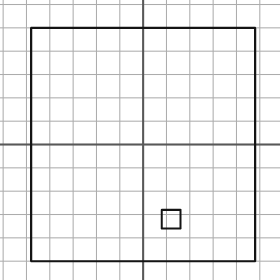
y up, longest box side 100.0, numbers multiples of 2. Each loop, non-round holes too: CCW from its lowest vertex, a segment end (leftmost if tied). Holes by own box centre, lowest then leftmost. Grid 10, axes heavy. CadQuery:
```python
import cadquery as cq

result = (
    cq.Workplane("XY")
    .moveTo(-48.0, -50.0)
    .lineTo(48.0, -50.0)
    .lineTo(48.0, 50.0)
    .lineTo(-48.0, 50.0)
    .close()
    .moveTo(8.0, -36.0)
    .lineTo(16.0, -36.0)
    .lineTo(16.0, -28.0)
    .lineTo(8.0, -28.0)
    .close()
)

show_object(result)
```